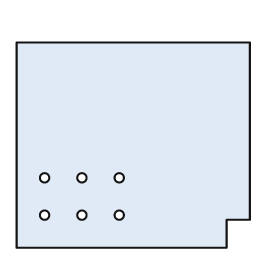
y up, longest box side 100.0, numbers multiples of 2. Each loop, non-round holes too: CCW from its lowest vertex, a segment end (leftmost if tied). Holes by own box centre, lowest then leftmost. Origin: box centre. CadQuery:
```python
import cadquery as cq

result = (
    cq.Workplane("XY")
    .moveTo(-50.0, -44.0)
    .lineTo(40.0, -44.0)
    .lineTo(40.0, -32.0)
    .lineTo(50.0, -32.0)
    .lineTo(50.0, 44.0)
    .lineTo(-50.0, 44.0)
    .close()
    .moveTo(-38.0, -30.0)
    .circle(2.0)
    .moveTo(-22.0, -30.0)
    .circle(2.0)
    .moveTo(-6.0, -30.0)
    .circle(2.0)
    .moveTo(-38.0, -14.0)
    .circle(2.0)
    .moveTo(-22.0, -14.0)
    .circle(2.0)
    .moveTo(-6.0, -14.0)
    .circle(2.0)
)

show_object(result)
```